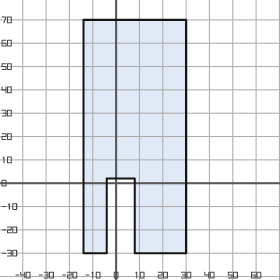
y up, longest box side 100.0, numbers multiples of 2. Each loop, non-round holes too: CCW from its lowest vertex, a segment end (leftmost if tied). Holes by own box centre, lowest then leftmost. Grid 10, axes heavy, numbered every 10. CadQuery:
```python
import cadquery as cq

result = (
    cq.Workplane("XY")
    .moveTo(-14.0, -30.0)
    .lineTo(-4.0, -30.0)
    .lineTo(-4.0, 2.0)
    .lineTo(8.0, 2.0)
    .lineTo(8.0, -30.0)
    .lineTo(30.0, -30.0)
    .lineTo(30.0, 70.0)
    .lineTo(-14.0, 70.0)
    .close()
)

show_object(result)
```